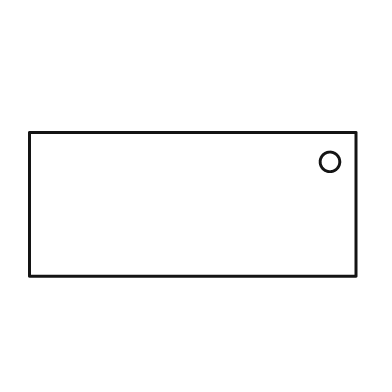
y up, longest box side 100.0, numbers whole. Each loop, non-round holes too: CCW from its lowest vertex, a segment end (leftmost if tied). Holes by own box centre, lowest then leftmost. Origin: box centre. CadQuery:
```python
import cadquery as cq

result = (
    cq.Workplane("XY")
    .moveTo(-50.0, -22.0)
    .lineTo(50.0, -22.0)
    .lineTo(50.0, 22.0)
    .lineTo(-50.0, 22.0)
    .close()
    .moveTo(42.0, 13.0)
    .circle(3.0)
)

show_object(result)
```